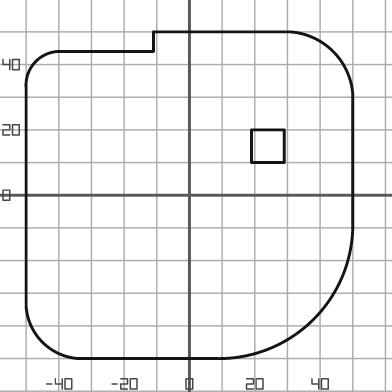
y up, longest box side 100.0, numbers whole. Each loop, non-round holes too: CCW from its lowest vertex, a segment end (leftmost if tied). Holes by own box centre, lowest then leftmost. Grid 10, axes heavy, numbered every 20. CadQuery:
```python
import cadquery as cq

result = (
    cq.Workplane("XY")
    .moveTo(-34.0, -50.0)
    .lineTo(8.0, -50.0)
    .threePointArc((38.0, -38.0), (50.0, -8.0))
    .lineTo(50.0, 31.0)
    .threePointArc((44.0, 44.0), (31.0, 50.0))
    .lineTo(-11.0, 50.0)
    .lineTo(-11.0, 44.0)
    .lineTo(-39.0, 44.0)
    .threePointArc((-47.0, 41.0), (-50.0, 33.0))
    .lineTo(-50.0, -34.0)
    .threePointArc((-45.0, -45.0), (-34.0, -50.0))
    .close()
    .moveTo(19.0, 10.0)
    .lineTo(29.0, 10.0)
    .lineTo(29.0, 20.0)
    .lineTo(19.0, 20.0)
    .close()
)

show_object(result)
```